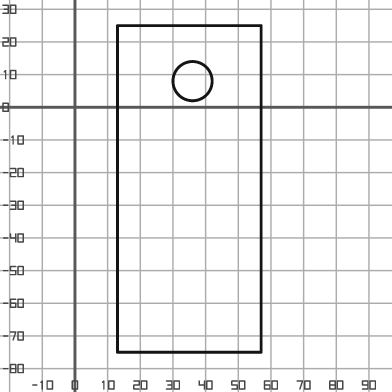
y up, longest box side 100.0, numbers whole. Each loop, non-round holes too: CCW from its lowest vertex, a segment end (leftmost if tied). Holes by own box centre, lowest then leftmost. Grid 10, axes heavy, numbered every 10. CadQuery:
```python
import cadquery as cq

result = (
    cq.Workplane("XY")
    .moveTo(13.0, -75.0)
    .lineTo(57.0, -75.0)
    .lineTo(57.0, 25.0)
    .lineTo(13.0, 25.0)
    .close()
    .moveTo(36.0, 8.0)
    .circle(6.0)
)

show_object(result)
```